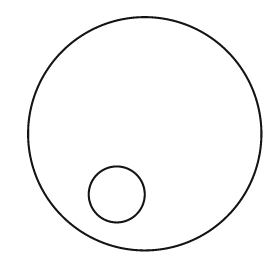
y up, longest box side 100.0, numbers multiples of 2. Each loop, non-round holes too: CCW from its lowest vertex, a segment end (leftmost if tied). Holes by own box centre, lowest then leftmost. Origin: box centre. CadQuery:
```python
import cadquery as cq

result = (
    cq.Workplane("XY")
    .moveTo(0.0, 0.0)
    .circle(50.0)
    .moveTo(-12.0, -26.0)
    .circle(12.0)
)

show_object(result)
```